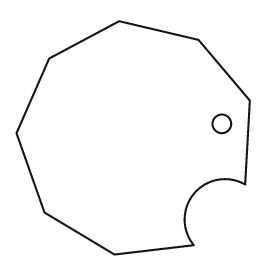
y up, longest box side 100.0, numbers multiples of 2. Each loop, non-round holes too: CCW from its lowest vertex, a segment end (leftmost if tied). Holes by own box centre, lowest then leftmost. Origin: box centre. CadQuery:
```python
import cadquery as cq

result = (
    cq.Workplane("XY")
    .moveTo(-8.0, -50.0)
    .lineTo(26.0, -46.0)
    .threePointArc((26.0, -24.0), (48.0, -20.0))
    .lineTo(50.0, 16.0)
    .lineTo(28.0, 42.0)
    .lineTo(-6.0, 50.0)
    .lineTo(-36.0, 34.0)
    .lineTo(-50.0, 2.0)
    .lineTo(-38.0, -32.0)
    .close()
    .moveTo(38.0, 6.0)
    .circle(4.0)
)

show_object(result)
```